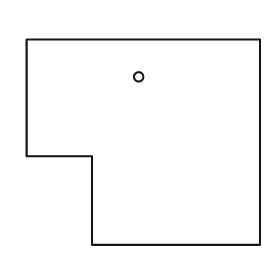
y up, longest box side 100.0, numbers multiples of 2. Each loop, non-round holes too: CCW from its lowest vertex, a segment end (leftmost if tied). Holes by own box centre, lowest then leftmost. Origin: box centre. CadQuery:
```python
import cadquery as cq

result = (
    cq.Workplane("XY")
    .moveTo(-22.0, -44.0)
    .lineTo(50.0, -44.0)
    .lineTo(50.0, 44.0)
    .lineTo(-50.0, 44.0)
    .lineTo(-50.0, -6.0)
    .lineTo(-22.0, -6.0)
    .close()
    .moveTo(-2.0, 28.0)
    .circle(2.0)
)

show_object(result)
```